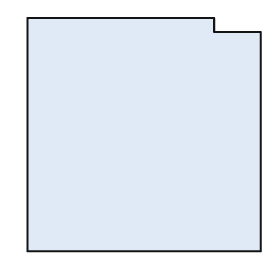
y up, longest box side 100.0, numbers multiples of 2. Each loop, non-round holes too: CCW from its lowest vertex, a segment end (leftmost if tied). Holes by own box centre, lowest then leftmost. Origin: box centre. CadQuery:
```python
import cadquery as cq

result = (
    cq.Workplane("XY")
    .moveTo(-50.0, -50.0)
    .lineTo(50.0, -50.0)
    .lineTo(50.0, 44.0)
    .lineTo(30.0, 44.0)
    .lineTo(30.0, 50.0)
    .lineTo(-50.0, 50.0)
    .close()
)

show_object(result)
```